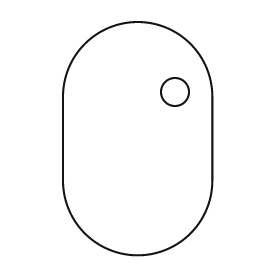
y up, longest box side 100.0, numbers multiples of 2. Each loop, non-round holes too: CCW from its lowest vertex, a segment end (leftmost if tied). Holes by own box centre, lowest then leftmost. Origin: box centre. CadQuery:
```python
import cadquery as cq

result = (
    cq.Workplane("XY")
    .moveTo(-32.0, -18.0)
    .threePointArc((0.0, -50.0), (32.0, -18.0))
    .lineTo(32.0, 18.0)
    .threePointArc((0.0, 50.0), (-32.0, 18.0))
    .close()
    .moveTo(16.0, 20.0)
    .circle(6.0)
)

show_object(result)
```